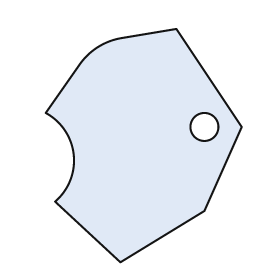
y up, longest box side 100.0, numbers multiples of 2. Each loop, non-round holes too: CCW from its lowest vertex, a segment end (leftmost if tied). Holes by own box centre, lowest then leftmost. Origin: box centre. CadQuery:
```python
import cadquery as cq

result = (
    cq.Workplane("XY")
    .moveTo(-10.0, -50.0)
    .lineTo(26.0, -28.0)
    .lineTo(42.0, 8.0)
    .lineTo(14.0, 50.0)
    .lineTo(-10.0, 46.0)
    .threePointArc((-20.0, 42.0), (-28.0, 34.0))
    .lineTo(-42.0, 14.0)
    .threePointArc((-30.0, -4.0), (-38.0, -24.0))
    .close()
    .moveTo(26.0, 8.0)
    .circle(6.0)
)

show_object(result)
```